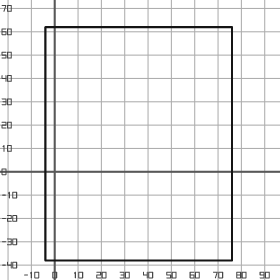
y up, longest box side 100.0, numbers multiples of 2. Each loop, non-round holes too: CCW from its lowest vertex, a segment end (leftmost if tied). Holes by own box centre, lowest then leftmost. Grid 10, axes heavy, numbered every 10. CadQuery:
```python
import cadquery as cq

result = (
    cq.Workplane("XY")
    .moveTo(-4.0, -38.0)
    .lineTo(76.0, -38.0)
    .lineTo(76.0, 62.0)
    .lineTo(-4.0, 62.0)
    .close()
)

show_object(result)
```